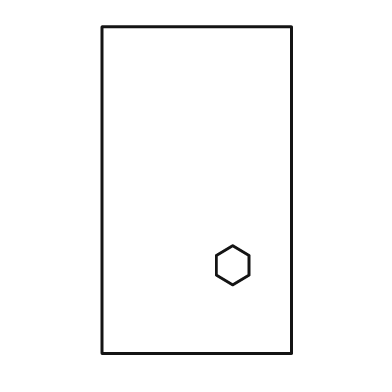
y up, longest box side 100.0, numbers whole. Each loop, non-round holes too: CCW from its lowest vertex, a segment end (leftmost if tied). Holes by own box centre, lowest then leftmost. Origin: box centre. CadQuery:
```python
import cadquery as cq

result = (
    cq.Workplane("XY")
    .moveTo(-29.0, -50.0)
    .lineTo(29.0, -50.0)
    .lineTo(29.0, 50.0)
    .lineTo(-29.0, 50.0)
    .close()
    .moveTo(11.0, -29.0)
    .lineTo(16.0, -26.0)
    .lineTo(16.0, -20.0)
    .lineTo(11.0, -17.0)
    .lineTo(6.0, -20.0)
    .lineTo(6.0, -26.0)
    .close()
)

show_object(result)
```